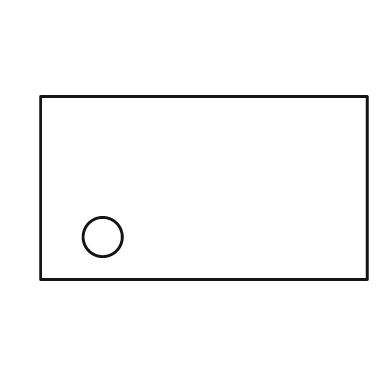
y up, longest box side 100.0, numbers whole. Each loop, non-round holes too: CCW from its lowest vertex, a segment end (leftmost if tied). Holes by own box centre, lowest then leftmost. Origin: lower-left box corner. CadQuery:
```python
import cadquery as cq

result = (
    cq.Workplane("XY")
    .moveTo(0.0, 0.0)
    .lineTo(100.0, 0.0)
    .lineTo(100.0, 56.0)
    .lineTo(0.0, 56.0)
    .close()
    .moveTo(19.0, 13.0)
    .circle(6.0)
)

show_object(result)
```